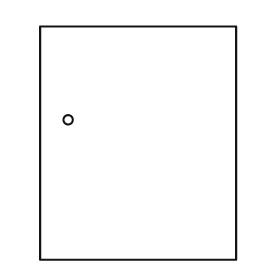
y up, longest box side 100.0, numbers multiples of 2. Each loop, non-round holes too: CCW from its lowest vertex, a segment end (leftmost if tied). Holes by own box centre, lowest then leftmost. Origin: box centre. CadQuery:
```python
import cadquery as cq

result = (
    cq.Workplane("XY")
    .moveTo(-42.0, -50.0)
    .lineTo(42.0, -50.0)
    .lineTo(42.0, 50.0)
    .lineTo(-42.0, 50.0)
    .close()
    .moveTo(-30.0, 10.0)
    .circle(2.0)
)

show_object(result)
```